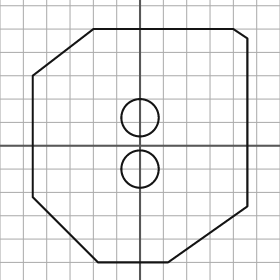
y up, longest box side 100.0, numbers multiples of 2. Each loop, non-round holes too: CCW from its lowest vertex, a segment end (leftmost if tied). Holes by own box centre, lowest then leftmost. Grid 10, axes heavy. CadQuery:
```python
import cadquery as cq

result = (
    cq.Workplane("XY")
    .moveTo(-18.0, -50.0)
    .lineTo(12.0, -50.0)
    .lineTo(46.0, -26.0)
    .lineTo(46.0, 46.0)
    .lineTo(40.0, 50.0)
    .lineTo(-20.0, 50.0)
    .lineTo(-46.0, 30.0)
    .lineTo(-46.0, -22.0)
    .close()
    .moveTo(0.0, -10.0)
    .circle(8.0)
    .moveTo(0.0, 12.0)
    .circle(8.0)
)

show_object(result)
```